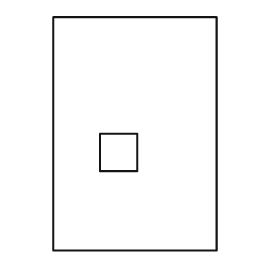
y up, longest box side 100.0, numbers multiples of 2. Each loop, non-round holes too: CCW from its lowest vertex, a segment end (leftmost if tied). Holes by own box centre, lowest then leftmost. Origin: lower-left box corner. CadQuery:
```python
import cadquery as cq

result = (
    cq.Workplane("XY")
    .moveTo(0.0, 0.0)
    .lineTo(70.0, 0.0)
    .lineTo(70.0, 100.0)
    .lineTo(0.0, 100.0)
    .close()
    .moveTo(20.0, 34.0)
    .lineTo(36.0, 34.0)
    .lineTo(36.0, 50.0)
    .lineTo(20.0, 50.0)
    .close()
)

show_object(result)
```